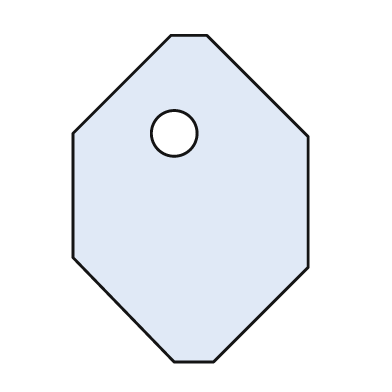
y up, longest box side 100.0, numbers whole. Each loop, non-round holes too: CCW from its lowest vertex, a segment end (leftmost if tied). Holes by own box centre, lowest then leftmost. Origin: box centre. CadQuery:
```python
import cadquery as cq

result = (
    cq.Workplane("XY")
    .moveTo(-5.0, -50.0)
    .lineTo(7.0, -50.0)
    .lineTo(36.0, -21.0)
    .lineTo(36.0, 19.0)
    .lineTo(5.0, 50.0)
    .lineTo(-6.0, 50.0)
    .lineTo(-36.0, 20.0)
    .lineTo(-36.0, -18.0)
    .close()
    .moveTo(-5.0, 20.0)
    .circle(7.0)
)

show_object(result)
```